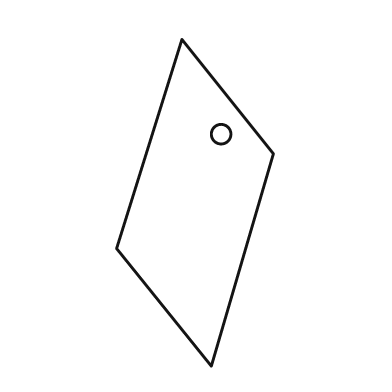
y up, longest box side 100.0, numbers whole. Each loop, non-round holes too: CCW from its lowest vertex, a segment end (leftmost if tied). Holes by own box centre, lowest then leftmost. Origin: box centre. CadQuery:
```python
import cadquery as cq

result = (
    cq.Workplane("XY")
    .moveTo(5.0, -50.0)
    .lineTo(24.0, 15.0)
    .lineTo(-4.0, 50.0)
    .lineTo(-24.0, -14.0)
    .close()
    .moveTo(8.0, 21.0)
    .circle(3.0)
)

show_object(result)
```